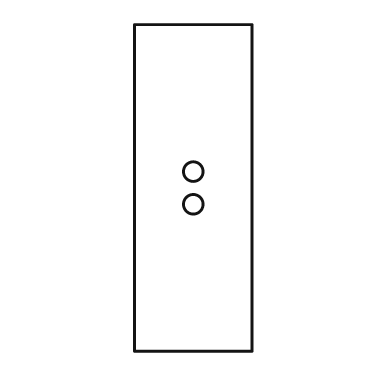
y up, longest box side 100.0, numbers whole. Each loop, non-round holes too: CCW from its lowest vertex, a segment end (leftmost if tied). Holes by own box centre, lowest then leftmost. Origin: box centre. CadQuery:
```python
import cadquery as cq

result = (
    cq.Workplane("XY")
    .moveTo(-18.0, -50.0)
    .lineTo(18.0, -50.0)
    .lineTo(18.0, 50.0)
    .lineTo(-18.0, 50.0)
    .close()
    .moveTo(0.0, -5.0)
    .circle(3.0)
    .moveTo(0.0, 5.0)
    .circle(3.0)
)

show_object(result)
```